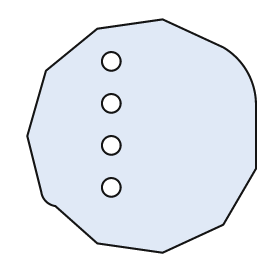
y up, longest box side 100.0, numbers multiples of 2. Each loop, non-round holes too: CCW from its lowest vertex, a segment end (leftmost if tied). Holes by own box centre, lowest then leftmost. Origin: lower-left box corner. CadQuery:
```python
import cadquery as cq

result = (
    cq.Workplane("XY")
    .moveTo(58.0, 0.0)
    .lineTo(84.0, 12.0)
    .lineTo(98.0, 36.0)
    .lineTo(98.0, 64.0)
    .threePointArc((94.0, 78.0), (84.0, 88.0))
    .lineTo(58.0, 100.0)
    .lineTo(30.0, 96.0)
    .lineTo(8.0, 78.0)
    .lineTo(0.0, 50.0)
    .lineTo(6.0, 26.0)
    .threePointArc((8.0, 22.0), (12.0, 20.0))
    .lineTo(30.0, 4.0)
    .close()
    .moveTo(36.0, 28.0)
    .circle(4.0)
    .moveTo(36.0, 46.0)
    .circle(4.0)
    .moveTo(36.0, 64.0)
    .circle(4.0)
    .moveTo(36.0, 82.0)
    .circle(4.0)
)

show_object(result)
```